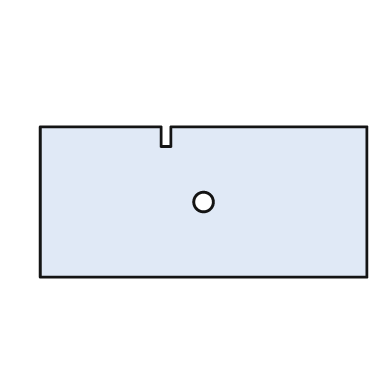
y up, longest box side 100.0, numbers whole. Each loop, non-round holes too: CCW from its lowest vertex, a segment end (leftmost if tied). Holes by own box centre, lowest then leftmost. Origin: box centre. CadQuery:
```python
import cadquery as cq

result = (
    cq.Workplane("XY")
    .moveTo(-50.0, -23.0)
    .lineTo(50.0, -23.0)
    .lineTo(50.0, 23.0)
    .lineTo(-10.0, 23.0)
    .lineTo(-10.0, 17.0)
    .lineTo(-13.0, 17.0)
    .lineTo(-13.0, 23.0)
    .lineTo(-50.0, 23.0)
    .close()
    .moveTo(0.0, 0.0)
    .circle(3.0)
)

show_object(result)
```